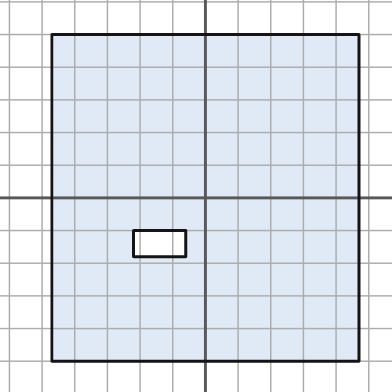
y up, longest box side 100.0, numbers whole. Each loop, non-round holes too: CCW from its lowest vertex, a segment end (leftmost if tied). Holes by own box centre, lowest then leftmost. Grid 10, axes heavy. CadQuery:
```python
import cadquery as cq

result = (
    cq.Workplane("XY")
    .moveTo(-47.0, -50.0)
    .lineTo(47.0, -50.0)
    .lineTo(47.0, 50.0)
    .lineTo(-47.0, 50.0)
    .close()
    .moveTo(-22.0, -18.0)
    .lineTo(-6.0, -18.0)
    .lineTo(-6.0, -10.0)
    .lineTo(-22.0, -10.0)
    .close()
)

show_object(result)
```